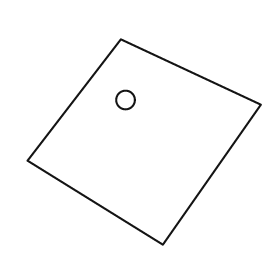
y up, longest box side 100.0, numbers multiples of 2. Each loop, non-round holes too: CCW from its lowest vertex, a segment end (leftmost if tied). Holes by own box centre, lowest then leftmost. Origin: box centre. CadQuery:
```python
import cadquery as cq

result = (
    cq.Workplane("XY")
    .moveTo(8.0, -44.0)
    .lineTo(50.0, 16.0)
    .lineTo(-10.0, 44.0)
    .lineTo(-50.0, -8.0)
    .close()
    .moveTo(-8.0, 18.0)
    .circle(4.0)
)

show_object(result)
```